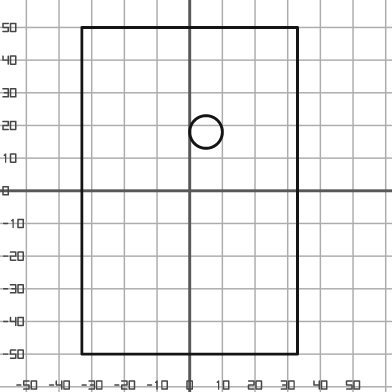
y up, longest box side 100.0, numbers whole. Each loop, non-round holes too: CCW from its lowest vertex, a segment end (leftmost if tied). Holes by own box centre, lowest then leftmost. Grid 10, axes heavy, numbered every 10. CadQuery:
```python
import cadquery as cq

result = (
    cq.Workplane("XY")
    .moveTo(-33.0, -50.0)
    .lineTo(33.0, -50.0)
    .lineTo(33.0, 50.0)
    .lineTo(-33.0, 50.0)
    .close()
    .moveTo(5.0, 18.0)
    .circle(5.0)
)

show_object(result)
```